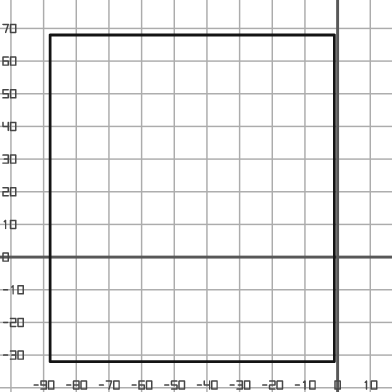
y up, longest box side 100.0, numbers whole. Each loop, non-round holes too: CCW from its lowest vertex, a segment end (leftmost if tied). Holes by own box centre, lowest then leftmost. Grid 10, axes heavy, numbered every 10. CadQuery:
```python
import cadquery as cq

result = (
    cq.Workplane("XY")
    .moveTo(-88.0, -32.0)
    .lineTo(-1.0, -32.0)
    .lineTo(-1.0, 68.0)
    .lineTo(-88.0, 68.0)
    .close()
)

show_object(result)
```